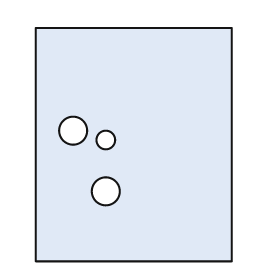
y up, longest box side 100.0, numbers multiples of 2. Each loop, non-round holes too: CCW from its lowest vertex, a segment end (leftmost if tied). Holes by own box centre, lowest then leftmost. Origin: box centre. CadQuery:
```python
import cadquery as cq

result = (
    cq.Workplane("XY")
    .moveTo(-42.0, -50.0)
    .lineTo(42.0, -50.0)
    .lineTo(42.0, 50.0)
    .lineTo(-42.0, 50.0)
    .close()
    .moveTo(-12.0, -20.0)
    .circle(6.0)
    .moveTo(-12.0, 2.0)
    .circle(4.0)
    .moveTo(-26.0, 6.0)
    .circle(6.0)
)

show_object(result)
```